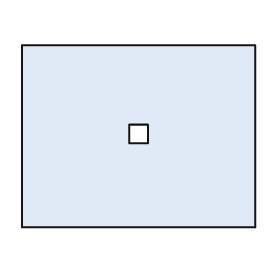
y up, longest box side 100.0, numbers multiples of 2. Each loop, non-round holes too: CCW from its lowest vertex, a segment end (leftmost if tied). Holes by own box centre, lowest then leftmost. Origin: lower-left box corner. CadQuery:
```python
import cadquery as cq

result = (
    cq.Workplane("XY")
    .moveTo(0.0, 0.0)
    .lineTo(100.0, 0.0)
    .lineTo(100.0, 78.0)
    .lineTo(0.0, 78.0)
    .close()
    .moveTo(46.0, 36.0)
    .lineTo(54.0, 36.0)
    .lineTo(54.0, 44.0)
    .lineTo(46.0, 44.0)
    .close()
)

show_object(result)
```